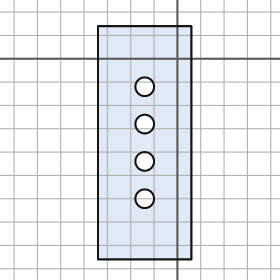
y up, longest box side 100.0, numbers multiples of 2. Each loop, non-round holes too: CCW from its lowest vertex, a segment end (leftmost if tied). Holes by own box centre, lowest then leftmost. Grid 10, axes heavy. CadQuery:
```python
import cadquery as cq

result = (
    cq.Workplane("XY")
    .moveTo(-34.0, -86.0)
    .lineTo(6.0, -86.0)
    .lineTo(6.0, 14.0)
    .lineTo(-34.0, 14.0)
    .close()
    .moveTo(-14.0, -60.0)
    .circle(4.0)
    .moveTo(-14.0, -44.0)
    .circle(4.0)
    .moveTo(-14.0, -28.0)
    .circle(4.0)
    .moveTo(-14.0, -12.0)
    .circle(4.0)
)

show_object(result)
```